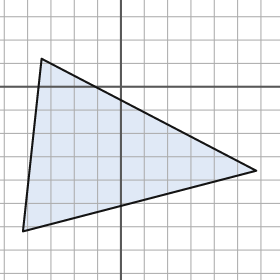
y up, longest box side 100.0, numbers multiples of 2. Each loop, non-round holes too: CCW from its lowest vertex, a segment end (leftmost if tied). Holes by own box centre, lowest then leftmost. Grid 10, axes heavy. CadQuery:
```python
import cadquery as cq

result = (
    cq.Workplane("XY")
    .moveTo(-42.0, -62.0)
    .lineTo(58.0, -36.0)
    .lineTo(-34.0, 12.0)
    .close()
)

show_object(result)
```